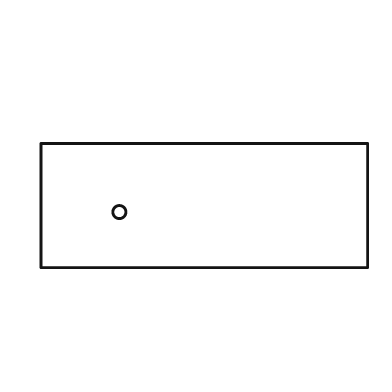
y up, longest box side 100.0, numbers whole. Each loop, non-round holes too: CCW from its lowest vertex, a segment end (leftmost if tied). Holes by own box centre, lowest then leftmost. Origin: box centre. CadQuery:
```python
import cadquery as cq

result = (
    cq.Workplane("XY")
    .moveTo(-50.0, -19.0)
    .lineTo(50.0, -19.0)
    .lineTo(50.0, 19.0)
    .lineTo(-50.0, 19.0)
    .close()
    .moveTo(-26.0, -2.0)
    .circle(2.0)
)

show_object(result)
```